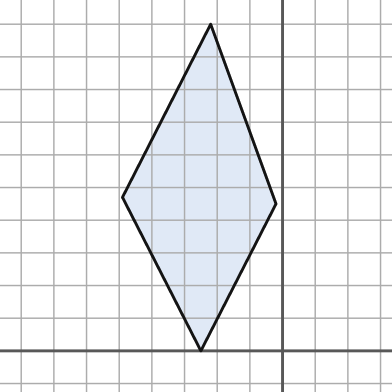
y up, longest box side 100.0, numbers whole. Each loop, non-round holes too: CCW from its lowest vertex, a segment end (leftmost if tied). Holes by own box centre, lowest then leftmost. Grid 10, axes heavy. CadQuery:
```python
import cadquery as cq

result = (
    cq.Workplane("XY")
    .moveTo(-25.0, 0.0)
    .lineTo(-2.0, 45.0)
    .lineTo(-22.0, 100.0)
    .lineTo(-49.0, 47.0)
    .close()
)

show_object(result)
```